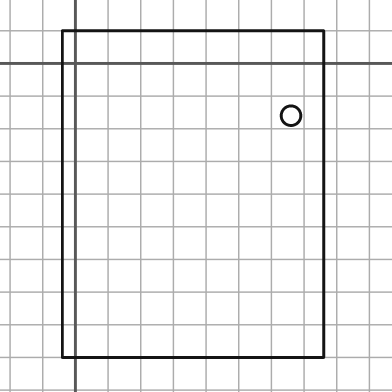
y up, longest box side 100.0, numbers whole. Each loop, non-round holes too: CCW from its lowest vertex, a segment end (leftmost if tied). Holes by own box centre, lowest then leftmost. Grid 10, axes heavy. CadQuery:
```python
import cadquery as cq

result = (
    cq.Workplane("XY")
    .moveTo(-4.0, -90.0)
    .lineTo(76.0, -90.0)
    .lineTo(76.0, 10.0)
    .lineTo(-4.0, 10.0)
    .close()
    .moveTo(66.0, -16.0)
    .circle(3.0)
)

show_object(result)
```